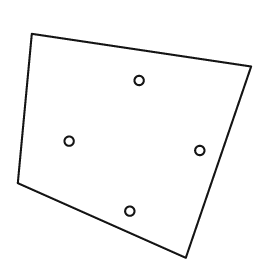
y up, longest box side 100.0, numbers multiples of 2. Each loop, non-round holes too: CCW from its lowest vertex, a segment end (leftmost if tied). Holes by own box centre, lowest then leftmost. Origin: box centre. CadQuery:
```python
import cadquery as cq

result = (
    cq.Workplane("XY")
    .moveTo(22.0, -48.0)
    .lineTo(50.0, 34.0)
    .lineTo(-44.0, 48.0)
    .lineTo(-50.0, -16.0)
    .close()
    .moveTo(-2.0, -28.0)
    .circle(2.0)
    .moveTo(28.0, -2.0)
    .circle(2.0)
    .moveTo(-28.0, 2.0)
    .circle(2.0)
    .moveTo(2.0, 28.0)
    .circle(2.0)
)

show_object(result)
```